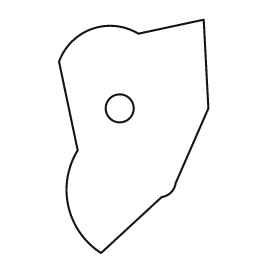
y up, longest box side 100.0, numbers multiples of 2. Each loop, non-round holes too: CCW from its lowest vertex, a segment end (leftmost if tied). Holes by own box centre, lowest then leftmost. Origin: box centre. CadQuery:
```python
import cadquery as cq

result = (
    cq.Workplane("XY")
    .moveTo(-14.0, -50.0)
    .lineTo(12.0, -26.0)
    .threePointArc((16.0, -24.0), (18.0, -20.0))
    .lineTo(32.0, 12.0)
    .lineTo(30.0, 50.0)
    .lineTo(2.0, 44.0)
    .threePointArc((-18.0, 46.0), (-32.0, 32.0))
    .lineTo(-24.0, -6.0)
    .threePointArc((-28.0, -30.0), (-14.0, -50.0))
    .close()
    .moveTo(-6.0, 12.0)
    .circle(6.0)
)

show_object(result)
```